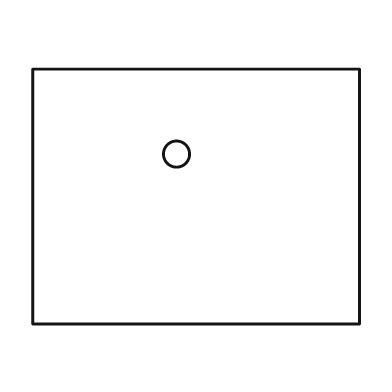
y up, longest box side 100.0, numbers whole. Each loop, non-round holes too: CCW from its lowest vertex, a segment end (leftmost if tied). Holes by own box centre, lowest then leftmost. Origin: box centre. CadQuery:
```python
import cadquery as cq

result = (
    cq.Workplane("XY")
    .moveTo(-50.0, -39.0)
    .lineTo(50.0, -39.0)
    .lineTo(50.0, 39.0)
    .lineTo(-50.0, 39.0)
    .close()
    .moveTo(-6.0, 13.0)
    .circle(4.0)
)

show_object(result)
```